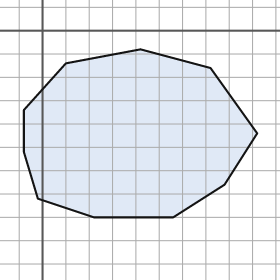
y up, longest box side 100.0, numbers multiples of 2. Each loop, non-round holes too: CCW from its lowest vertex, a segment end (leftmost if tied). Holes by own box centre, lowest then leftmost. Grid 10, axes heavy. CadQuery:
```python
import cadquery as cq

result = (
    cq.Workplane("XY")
    .moveTo(22.0, -80.0)
    .lineTo(56.0, -80.0)
    .lineTo(78.0, -66.0)
    .lineTo(92.0, -44.0)
    .lineTo(72.0, -16.0)
    .lineTo(42.0, -8.0)
    .lineTo(10.0, -14.0)
    .lineTo(-8.0, -34.0)
    .lineTo(-8.0, -52.0)
    .lineTo(-2.0, -72.0)
    .close()
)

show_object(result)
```